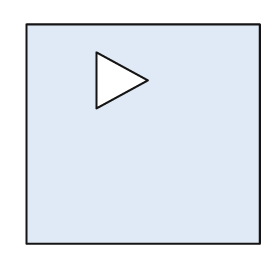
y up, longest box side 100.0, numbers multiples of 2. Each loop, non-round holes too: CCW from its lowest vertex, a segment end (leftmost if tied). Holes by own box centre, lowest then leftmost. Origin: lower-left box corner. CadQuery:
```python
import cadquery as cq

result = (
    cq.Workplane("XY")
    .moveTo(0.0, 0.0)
    .lineTo(100.0, 0.0)
    .lineTo(100.0, 94.0)
    .lineTo(0.0, 94.0)
    .close()
    .moveTo(30.0, 58.0)
    .lineTo(52.0, 70.0)
    .lineTo(30.0, 82.0)
    .close()
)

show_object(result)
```